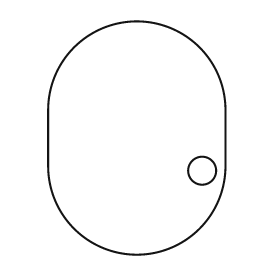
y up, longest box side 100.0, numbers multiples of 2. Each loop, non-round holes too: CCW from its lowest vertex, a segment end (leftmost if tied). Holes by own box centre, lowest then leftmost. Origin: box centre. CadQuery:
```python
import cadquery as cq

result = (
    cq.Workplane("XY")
    .moveTo(-38.0, -12.0)
    .threePointArc((0.0, -50.0), (38.0, -12.0))
    .lineTo(38.0, 12.0)
    .threePointArc((0.0, 50.0), (-38.0, 12.0))
    .close()
    .moveTo(28.0, -14.0)
    .circle(6.0)
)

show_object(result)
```